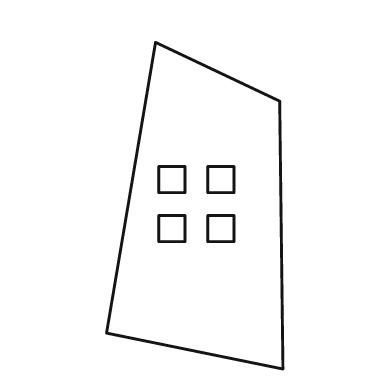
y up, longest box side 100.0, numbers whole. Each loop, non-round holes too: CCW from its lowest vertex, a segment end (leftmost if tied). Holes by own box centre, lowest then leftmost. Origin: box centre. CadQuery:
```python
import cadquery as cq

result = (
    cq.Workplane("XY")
    .moveTo(27.0, -50.0)
    .lineTo(26.0, 32.0)
    .lineTo(-12.0, 50.0)
    .lineTo(-27.0, -39.0)
    .close()
    .moveTo(-11.0, -11.0)
    .lineTo(-3.0, -11.0)
    .lineTo(-3.0, -3.0)
    .lineTo(-11.0, -3.0)
    .close()
    .moveTo(4.0, -11.0)
    .lineTo(12.0, -11.0)
    .lineTo(12.0, -3.0)
    .lineTo(4.0, -3.0)
    .close()
    .moveTo(-11.0, 4.0)
    .lineTo(-3.0, 4.0)
    .lineTo(-3.0, 12.0)
    .lineTo(-11.0, 12.0)
    .close()
    .moveTo(4.0, 4.0)
    .lineTo(12.0, 4.0)
    .lineTo(12.0, 12.0)
    .lineTo(4.0, 12.0)
    .close()
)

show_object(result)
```